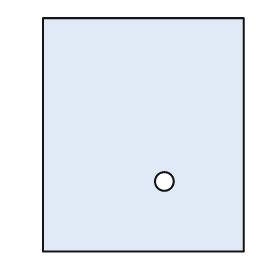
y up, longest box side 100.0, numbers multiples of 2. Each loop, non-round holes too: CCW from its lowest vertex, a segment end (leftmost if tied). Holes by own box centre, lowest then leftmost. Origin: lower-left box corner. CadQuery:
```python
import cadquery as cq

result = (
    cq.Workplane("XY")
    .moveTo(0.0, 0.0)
    .lineTo(86.0, 0.0)
    .lineTo(86.0, 100.0)
    .lineTo(0.0, 100.0)
    .close()
    .moveTo(52.0, 30.0)
    .circle(4.0)
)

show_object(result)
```